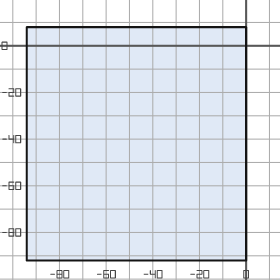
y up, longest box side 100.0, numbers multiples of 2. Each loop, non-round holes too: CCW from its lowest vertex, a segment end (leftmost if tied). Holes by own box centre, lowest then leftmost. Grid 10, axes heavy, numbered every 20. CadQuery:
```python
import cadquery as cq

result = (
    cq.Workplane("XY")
    .moveTo(-94.0, -92.0)
    .lineTo(0.0, -92.0)
    .lineTo(0.0, 8.0)
    .lineTo(-94.0, 8.0)
    .close()
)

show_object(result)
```